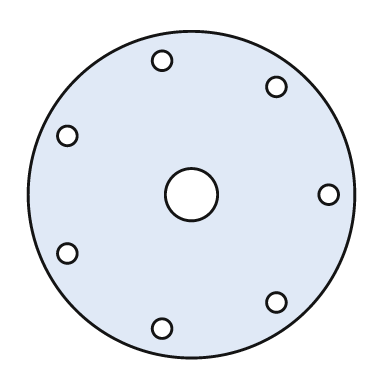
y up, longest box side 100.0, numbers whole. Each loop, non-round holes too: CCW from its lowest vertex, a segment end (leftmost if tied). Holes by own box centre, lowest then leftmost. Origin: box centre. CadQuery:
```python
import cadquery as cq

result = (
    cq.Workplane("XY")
    .moveTo(0.0, 0.0)
    .circle(50.0)
    .moveTo(-9.0, -41.0)
    .circle(3.0)
    .moveTo(26.0, -33.0)
    .circle(3.0)
    .moveTo(-38.0, -18.0)
    .circle(3.0)
    .moveTo(0.0, 0.0)
    .circle(8.0)
    .moveTo(42.0, 0.0)
    .circle(3.0)
    .moveTo(-38.0, 18.0)
    .circle(3.0)
    .moveTo(26.0, 33.0)
    .circle(3.0)
    .moveTo(-9.0, 41.0)
    .circle(3.0)
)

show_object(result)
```